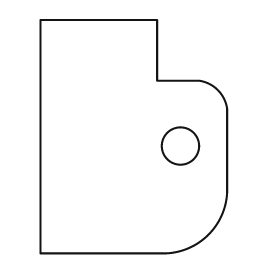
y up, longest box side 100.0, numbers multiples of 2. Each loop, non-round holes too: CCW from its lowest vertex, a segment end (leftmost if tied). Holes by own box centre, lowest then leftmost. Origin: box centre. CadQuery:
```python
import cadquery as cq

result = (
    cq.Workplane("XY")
    .moveTo(-40.0, -50.0)
    .lineTo(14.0, -50.0)
    .threePointArc((32.0, -42.0), (40.0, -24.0))
    .lineTo(40.0, 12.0)
    .threePointArc((36.0, 20.0), (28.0, 24.0))
    .lineTo(10.0, 24.0)
    .lineTo(10.0, 50.0)
    .lineTo(-40.0, 50.0)
    .close()
    .moveTo(20.0, -4.0)
    .circle(8.0)
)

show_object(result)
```